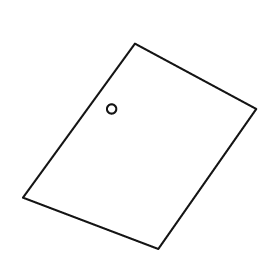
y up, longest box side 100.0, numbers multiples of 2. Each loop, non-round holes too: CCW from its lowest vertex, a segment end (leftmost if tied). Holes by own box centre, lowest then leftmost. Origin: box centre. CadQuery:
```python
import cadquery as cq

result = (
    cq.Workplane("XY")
    .moveTo(8.0, -44.0)
    .lineTo(50.0, 16.0)
    .lineTo(-2.0, 44.0)
    .lineTo(-50.0, -22.0)
    .close()
    .moveTo(-12.0, 16.0)
    .circle(2.0)
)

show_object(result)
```